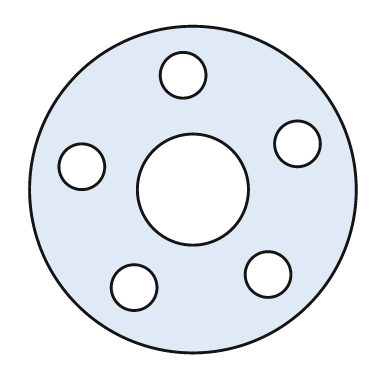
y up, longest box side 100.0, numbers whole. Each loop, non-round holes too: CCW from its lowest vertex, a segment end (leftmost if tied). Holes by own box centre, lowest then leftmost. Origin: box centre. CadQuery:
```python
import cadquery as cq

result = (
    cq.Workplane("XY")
    .moveTo(0.0, 0.0)
    .circle(50.0)
    .moveTo(-18.0, -30.0)
    .circle(7.0)
    .moveTo(23.0, -26.0)
    .circle(7.0)
    .moveTo(0.0, 0.0)
    .circle(17.0)
    .moveTo(-34.0, 7.0)
    .circle(7.0)
    .moveTo(32.0, 14.0)
    .circle(7.0)
    .moveTo(-3.0, 35.0)
    .circle(7.0)
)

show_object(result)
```